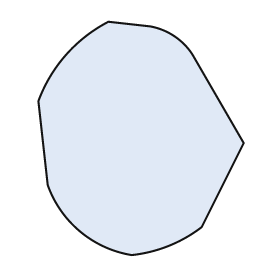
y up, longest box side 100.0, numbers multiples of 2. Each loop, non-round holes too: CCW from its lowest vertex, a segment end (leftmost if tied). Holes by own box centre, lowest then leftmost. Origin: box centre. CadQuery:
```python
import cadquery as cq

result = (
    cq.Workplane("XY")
    .moveTo(-4.0, -50.0)
    .threePointArc((12.0, -46.0), (26.0, -38.0))
    .lineTo(44.0, -2.0)
    .lineTo(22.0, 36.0)
    .threePointArc((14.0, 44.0), (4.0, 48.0))
    .lineTo(-14.0, 50.0)
    .threePointArc((-32.0, 36.0), (-44.0, 16.0))
    .lineTo(-40.0, -20.0)
    .threePointArc((-26.0, -40.0), (-4.0, -50.0))
    .close()
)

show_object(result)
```